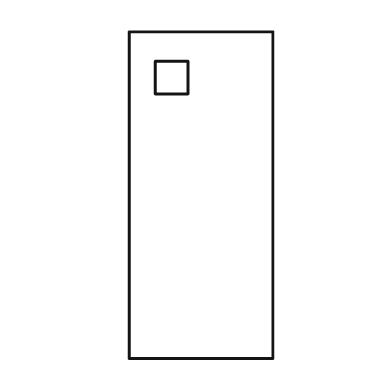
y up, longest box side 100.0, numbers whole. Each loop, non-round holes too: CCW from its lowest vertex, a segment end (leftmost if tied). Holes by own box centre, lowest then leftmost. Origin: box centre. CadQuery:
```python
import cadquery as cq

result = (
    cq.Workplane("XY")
    .moveTo(-22.0, -50.0)
    .lineTo(22.0, -50.0)
    .lineTo(22.0, 50.0)
    .lineTo(-22.0, 50.0)
    .close()
    .moveTo(-14.0, 31.0)
    .lineTo(-4.0, 31.0)
    .lineTo(-4.0, 41.0)
    .lineTo(-14.0, 41.0)
    .close()
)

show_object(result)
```